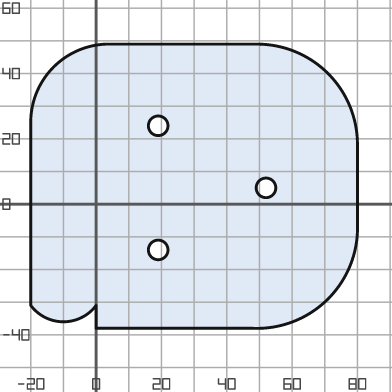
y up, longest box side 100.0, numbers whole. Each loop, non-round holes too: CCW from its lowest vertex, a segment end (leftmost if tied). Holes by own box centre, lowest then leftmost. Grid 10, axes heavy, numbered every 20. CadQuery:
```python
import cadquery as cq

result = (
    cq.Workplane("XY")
    .moveTo(0.0, -38.0)
    .lineTo(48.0, -38.0)
    .threePointArc((71.0, -29.0), (80.0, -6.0))
    .lineTo(80.0, 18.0)
    .threePointArc((71.0, 40.0), (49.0, 49.0))
    .lineTo(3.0, 49.0)
    .threePointArc((-13.0, 42.0), (-20.0, 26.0))
    .lineTo(-20.0, -31.0)
    .threePointArc((-10.0, -36.0), (0.0, -31.0))
    .close()
    .moveTo(19.0, -14.0)
    .circle(3.0)
    .moveTo(52.0, 5.0)
    .circle(3.0)
    .moveTo(19.0, 24.0)
    .circle(3.0)
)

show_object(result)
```